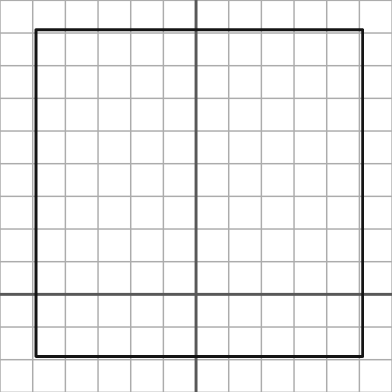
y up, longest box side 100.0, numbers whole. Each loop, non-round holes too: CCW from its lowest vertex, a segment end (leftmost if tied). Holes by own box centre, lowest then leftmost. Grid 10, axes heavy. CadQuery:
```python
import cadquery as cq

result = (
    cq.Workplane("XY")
    .moveTo(-49.0, -19.0)
    .lineTo(51.0, -19.0)
    .lineTo(51.0, 81.0)
    .lineTo(-49.0, 81.0)
    .close()
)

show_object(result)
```